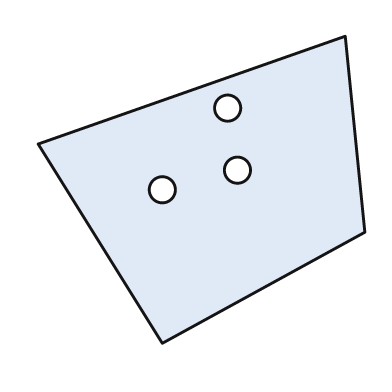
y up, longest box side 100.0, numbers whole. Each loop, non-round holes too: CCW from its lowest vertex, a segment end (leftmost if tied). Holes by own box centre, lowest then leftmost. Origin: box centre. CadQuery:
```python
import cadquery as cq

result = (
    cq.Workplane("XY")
    .moveTo(-12.0, -47.0)
    .lineTo(50.0, -13.0)
    .lineTo(44.0, 47.0)
    .lineTo(-50.0, 14.0)
    .close()
    .moveTo(-12.0, 0.0)
    .circle(4.0)
    .moveTo(11.0, 6.0)
    .circle(4.0)
    .moveTo(8.0, 25.0)
    .circle(4.0)
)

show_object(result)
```